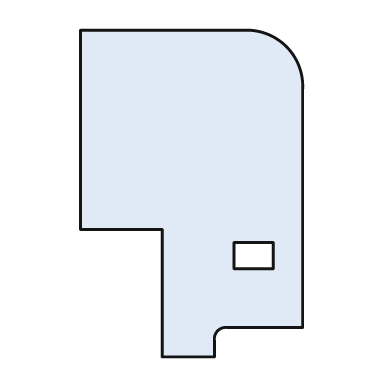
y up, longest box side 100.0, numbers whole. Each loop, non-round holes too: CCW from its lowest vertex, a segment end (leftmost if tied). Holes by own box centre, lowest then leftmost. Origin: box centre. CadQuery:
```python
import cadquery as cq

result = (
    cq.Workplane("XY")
    .moveTo(-9.0, -50.0)
    .lineTo(7.0, -50.0)
    .lineTo(7.0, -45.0)
    .threePointArc((8.0, -42.0), (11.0, -41.0))
    .lineTo(34.0, -41.0)
    .lineTo(34.0, 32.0)
    .threePointArc((29.0, 45.0), (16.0, 50.0))
    .lineTo(-34.0, 50.0)
    .lineTo(-34.0, -11.0)
    .lineTo(-9.0, -11.0)
    .close()
    .moveTo(13.0, -23.0)
    .lineTo(25.0, -23.0)
    .lineTo(25.0, -15.0)
    .lineTo(13.0, -15.0)
    .close()
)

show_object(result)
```